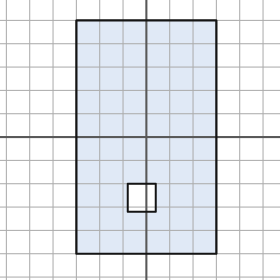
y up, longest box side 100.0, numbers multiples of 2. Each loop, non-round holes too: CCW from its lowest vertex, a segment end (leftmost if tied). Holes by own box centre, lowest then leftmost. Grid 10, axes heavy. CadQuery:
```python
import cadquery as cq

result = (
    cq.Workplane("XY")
    .moveTo(-30.0, -50.0)
    .lineTo(30.0, -50.0)
    .lineTo(30.0, 50.0)
    .lineTo(-30.0, 50.0)
    .close()
    .moveTo(-8.0, -32.0)
    .lineTo(4.0, -32.0)
    .lineTo(4.0, -20.0)
    .lineTo(-8.0, -20.0)
    .close()
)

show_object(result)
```